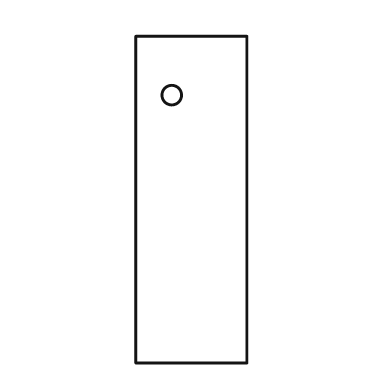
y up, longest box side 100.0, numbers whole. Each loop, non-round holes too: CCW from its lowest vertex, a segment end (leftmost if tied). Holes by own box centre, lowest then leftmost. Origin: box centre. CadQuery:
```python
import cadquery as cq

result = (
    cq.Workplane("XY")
    .moveTo(-17.0, -50.0)
    .lineTo(17.0, -50.0)
    .lineTo(17.0, 50.0)
    .lineTo(-17.0, 50.0)
    .close()
    .moveTo(-6.0, 32.0)
    .circle(3.0)
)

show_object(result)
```